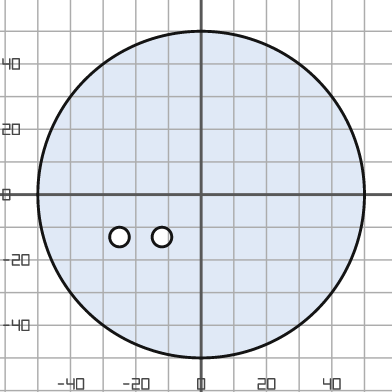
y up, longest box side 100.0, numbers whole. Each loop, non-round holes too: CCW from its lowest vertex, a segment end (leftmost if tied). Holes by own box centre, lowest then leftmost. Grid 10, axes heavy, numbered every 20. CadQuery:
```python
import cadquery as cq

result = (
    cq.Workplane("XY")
    .moveTo(0.0, 0.0)
    .circle(50.0)
    .moveTo(-25.0, -13.0)
    .circle(3.0)
    .moveTo(-12.0, -13.0)
    .circle(3.0)
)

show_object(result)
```